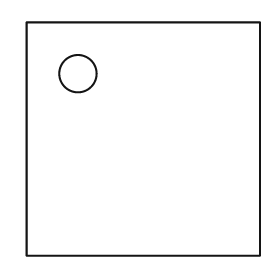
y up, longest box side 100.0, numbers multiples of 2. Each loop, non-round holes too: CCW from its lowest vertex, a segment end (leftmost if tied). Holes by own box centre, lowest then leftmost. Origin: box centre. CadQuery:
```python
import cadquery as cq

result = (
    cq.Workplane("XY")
    .moveTo(-50.0, -50.0)
    .lineTo(50.0, -50.0)
    .lineTo(50.0, 50.0)
    .lineTo(-50.0, 50.0)
    .close()
    .moveTo(-28.0, 28.0)
    .circle(8.0)
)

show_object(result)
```